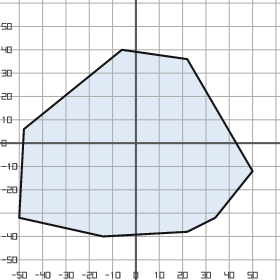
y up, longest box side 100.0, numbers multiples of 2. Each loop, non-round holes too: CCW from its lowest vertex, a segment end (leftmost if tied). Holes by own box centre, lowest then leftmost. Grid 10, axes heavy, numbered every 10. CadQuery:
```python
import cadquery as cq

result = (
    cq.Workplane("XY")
    .moveTo(-14.0, -40.0)
    .lineTo(22.0, -38.0)
    .lineTo(34.0, -32.0)
    .lineTo(50.0, -12.0)
    .lineTo(22.0, 36.0)
    .lineTo(-6.0, 40.0)
    .lineTo(-48.0, 6.0)
    .lineTo(-50.0, -32.0)
    .close()
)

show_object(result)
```